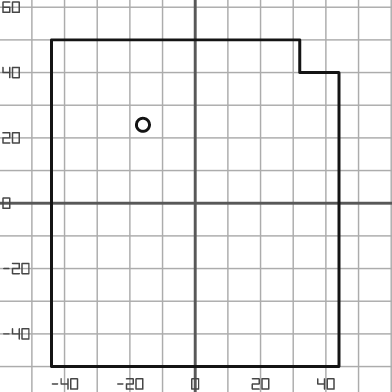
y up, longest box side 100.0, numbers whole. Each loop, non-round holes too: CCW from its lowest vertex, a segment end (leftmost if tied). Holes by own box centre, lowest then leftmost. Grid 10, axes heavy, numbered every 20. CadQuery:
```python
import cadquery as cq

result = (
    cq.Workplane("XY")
    .moveTo(-44.0, -50.0)
    .lineTo(44.0, -50.0)
    .lineTo(44.0, 40.0)
    .lineTo(32.0, 40.0)
    .lineTo(32.0, 50.0)
    .lineTo(-44.0, 50.0)
    .close()
    .moveTo(-16.0, 24.0)
    .circle(2.0)
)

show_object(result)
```